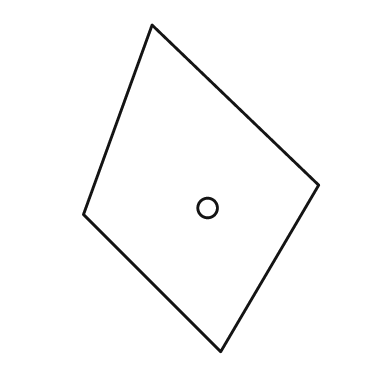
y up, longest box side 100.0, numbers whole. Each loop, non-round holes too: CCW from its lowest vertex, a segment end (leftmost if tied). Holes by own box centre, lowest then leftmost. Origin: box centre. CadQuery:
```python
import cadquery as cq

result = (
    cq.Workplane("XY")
    .moveTo(6.0, -50.0)
    .lineTo(36.0, 1.0)
    .lineTo(-15.0, 50.0)
    .lineTo(-36.0, -8.0)
    .close()
    .moveTo(2.0, -6.0)
    .circle(3.0)
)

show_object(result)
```